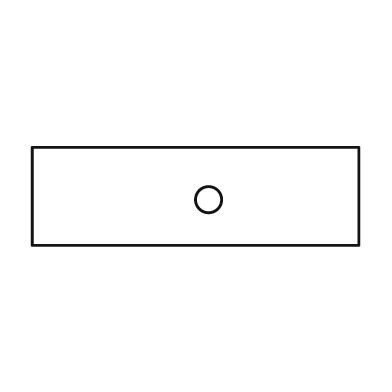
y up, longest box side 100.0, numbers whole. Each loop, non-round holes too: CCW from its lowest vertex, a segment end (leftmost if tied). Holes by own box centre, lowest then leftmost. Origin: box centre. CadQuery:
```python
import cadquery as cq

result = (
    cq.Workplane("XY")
    .moveTo(-50.0, -15.0)
    .lineTo(50.0, -15.0)
    .lineTo(50.0, 15.0)
    .lineTo(-50.0, 15.0)
    .close()
    .moveTo(4.0, -1.0)
    .circle(4.0)
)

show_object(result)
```